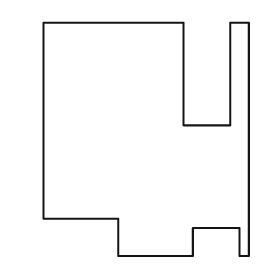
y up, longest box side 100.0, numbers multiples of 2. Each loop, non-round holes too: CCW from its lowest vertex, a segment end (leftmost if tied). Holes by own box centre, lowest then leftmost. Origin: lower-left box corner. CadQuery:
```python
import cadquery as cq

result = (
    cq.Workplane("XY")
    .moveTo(32.0, 0.0)
    .lineTo(64.0, 0.0)
    .lineTo(64.0, 12.0)
    .lineTo(84.0, 12.0)
    .lineTo(84.0, 0.0)
    .lineTo(88.0, 0.0)
    .lineTo(88.0, 100.0)
    .lineTo(80.0, 100.0)
    .lineTo(80.0, 56.0)
    .lineTo(60.0, 56.0)
    .lineTo(60.0, 100.0)
    .lineTo(0.0, 100.0)
    .lineTo(0.0, 16.0)
    .lineTo(32.0, 16.0)
    .close()
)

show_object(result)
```